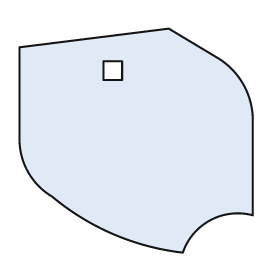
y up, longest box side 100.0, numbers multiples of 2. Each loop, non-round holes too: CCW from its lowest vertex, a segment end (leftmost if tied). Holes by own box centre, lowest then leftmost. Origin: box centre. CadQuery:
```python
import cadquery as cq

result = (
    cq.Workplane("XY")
    .moveTo(20.0, -48.0)
    .threePointArc((32.0, -34.0), (50.0, -32.0))
    .lineTo(50.0, 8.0)
    .threePointArc((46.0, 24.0), (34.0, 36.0))
    .lineTo(14.0, 48.0)
    .lineTo(-50.0, 40.0)
    .lineTo(-50.0, 0.0)
    .threePointArc((-46.0, -14.0), (-36.0, -24.0))
    .threePointArc((-10.0, -40.0), (20.0, -48.0))
    .close()
    .moveTo(-14.0, 26.0)
    .lineTo(-6.0, 26.0)
    .lineTo(-6.0, 34.0)
    .lineTo(-14.0, 34.0)
    .close()
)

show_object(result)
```